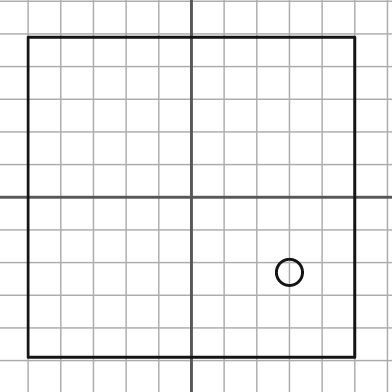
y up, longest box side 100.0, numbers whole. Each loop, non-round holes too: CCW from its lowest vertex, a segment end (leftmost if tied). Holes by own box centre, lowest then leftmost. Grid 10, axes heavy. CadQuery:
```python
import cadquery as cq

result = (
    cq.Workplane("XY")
    .moveTo(-50.0, -49.0)
    .lineTo(50.0, -49.0)
    .lineTo(50.0, 49.0)
    .lineTo(-50.0, 49.0)
    .close()
    .moveTo(30.0, -23.0)
    .circle(4.0)
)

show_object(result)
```